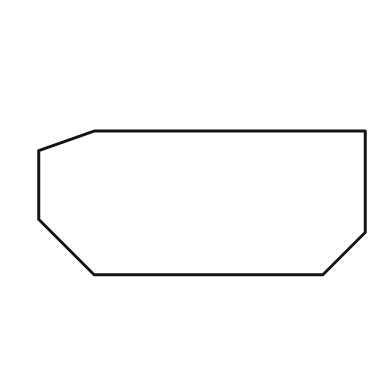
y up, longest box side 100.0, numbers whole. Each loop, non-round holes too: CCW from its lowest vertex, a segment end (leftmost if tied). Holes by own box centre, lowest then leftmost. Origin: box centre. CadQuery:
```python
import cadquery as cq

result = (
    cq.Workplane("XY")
    .moveTo(-33.0, -22.0)
    .lineTo(37.0, -22.0)
    .lineTo(50.0, -9.0)
    .lineTo(50.0, 22.0)
    .lineTo(-33.0, 22.0)
    .lineTo(-50.0, 16.0)
    .lineTo(-50.0, -5.0)
    .close()
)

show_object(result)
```